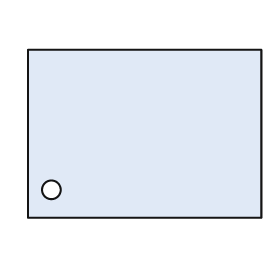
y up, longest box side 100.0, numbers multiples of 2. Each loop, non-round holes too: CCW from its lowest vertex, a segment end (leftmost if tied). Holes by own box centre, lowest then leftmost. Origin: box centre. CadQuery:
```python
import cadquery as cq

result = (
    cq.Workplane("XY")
    .moveTo(-50.0, -36.0)
    .lineTo(50.0, -36.0)
    .lineTo(50.0, 36.0)
    .lineTo(-50.0, 36.0)
    .close()
    .moveTo(-40.0, -24.0)
    .circle(4.0)
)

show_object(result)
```